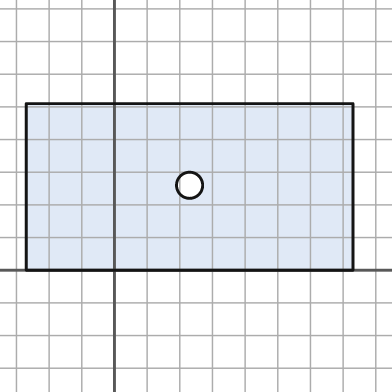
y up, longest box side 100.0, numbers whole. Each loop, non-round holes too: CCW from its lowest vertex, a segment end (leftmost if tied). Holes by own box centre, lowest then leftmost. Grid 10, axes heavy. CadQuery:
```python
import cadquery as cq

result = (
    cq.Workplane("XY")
    .moveTo(-27.0, 0.0)
    .lineTo(73.0, 0.0)
    .lineTo(73.0, 51.0)
    .lineTo(-27.0, 51.0)
    .close()
    .moveTo(23.0, 26.0)
    .circle(4.0)
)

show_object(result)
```